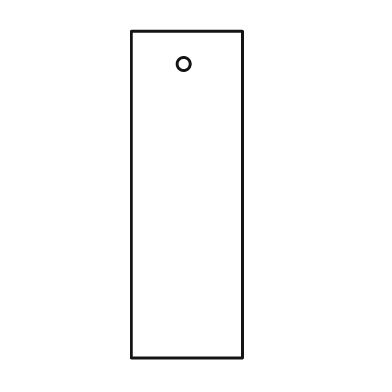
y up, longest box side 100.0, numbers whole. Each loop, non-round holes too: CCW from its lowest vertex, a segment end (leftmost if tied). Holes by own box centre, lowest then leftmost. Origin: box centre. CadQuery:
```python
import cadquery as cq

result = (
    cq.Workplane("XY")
    .moveTo(-17.0, -50.0)
    .lineTo(17.0, -50.0)
    .lineTo(17.0, 50.0)
    .lineTo(-17.0, 50.0)
    .close()
    .moveTo(-1.0, 40.0)
    .circle(2.0)
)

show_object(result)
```